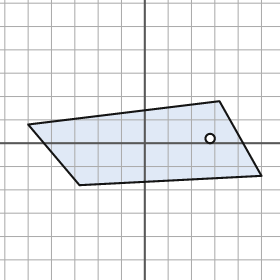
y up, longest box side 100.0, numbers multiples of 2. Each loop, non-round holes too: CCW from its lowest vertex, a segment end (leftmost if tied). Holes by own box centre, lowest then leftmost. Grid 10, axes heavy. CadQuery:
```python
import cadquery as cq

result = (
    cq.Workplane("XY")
    .moveTo(-28.0, -18.0)
    .lineTo(50.0, -14.0)
    .lineTo(32.0, 18.0)
    .lineTo(-50.0, 8.0)
    .close()
    .moveTo(28.0, 2.0)
    .circle(2.0)
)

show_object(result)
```